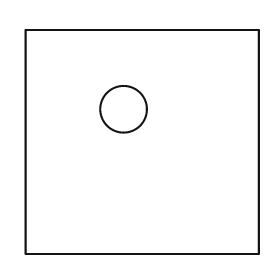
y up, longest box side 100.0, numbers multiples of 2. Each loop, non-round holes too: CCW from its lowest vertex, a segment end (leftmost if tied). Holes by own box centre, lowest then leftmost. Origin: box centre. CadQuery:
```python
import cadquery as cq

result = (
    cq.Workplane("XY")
    .moveTo(-50.0, -48.0)
    .lineTo(50.0, -48.0)
    .lineTo(50.0, 48.0)
    .lineTo(-50.0, 48.0)
    .close()
    .moveTo(-8.0, 14.0)
    .circle(10.0)
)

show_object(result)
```